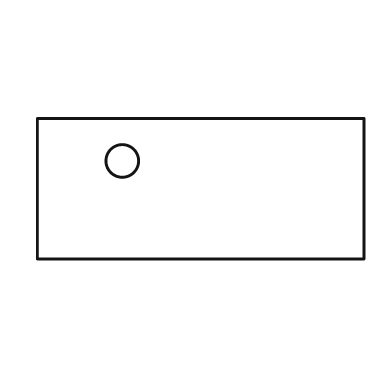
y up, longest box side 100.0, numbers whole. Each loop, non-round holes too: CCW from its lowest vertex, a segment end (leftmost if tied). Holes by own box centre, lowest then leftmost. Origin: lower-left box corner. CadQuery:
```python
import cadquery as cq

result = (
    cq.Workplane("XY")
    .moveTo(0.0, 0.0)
    .lineTo(100.0, 0.0)
    .lineTo(100.0, 43.0)
    .lineTo(0.0, 43.0)
    .close()
    .moveTo(26.0, 30.0)
    .circle(5.0)
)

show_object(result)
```